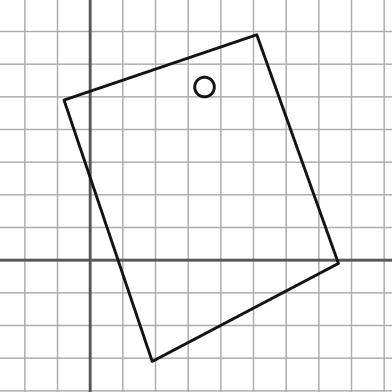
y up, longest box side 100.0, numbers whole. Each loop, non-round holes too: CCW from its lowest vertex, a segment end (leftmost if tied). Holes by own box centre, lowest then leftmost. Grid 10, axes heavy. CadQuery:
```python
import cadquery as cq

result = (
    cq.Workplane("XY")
    .moveTo(19.0, -31.0)
    .lineTo(76.0, -1.0)
    .lineTo(51.0, 69.0)
    .lineTo(-8.0, 49.0)
    .close()
    .moveTo(35.0, 53.0)
    .circle(3.0)
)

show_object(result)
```